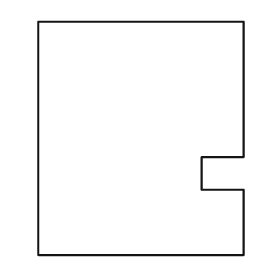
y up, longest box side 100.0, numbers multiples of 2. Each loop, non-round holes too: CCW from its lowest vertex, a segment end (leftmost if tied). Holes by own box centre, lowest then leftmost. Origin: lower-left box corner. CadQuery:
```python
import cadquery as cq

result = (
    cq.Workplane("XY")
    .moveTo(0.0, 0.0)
    .lineTo(88.0, 0.0)
    .lineTo(88.0, 28.0)
    .lineTo(70.0, 28.0)
    .lineTo(70.0, 42.0)
    .lineTo(88.0, 42.0)
    .lineTo(88.0, 100.0)
    .lineTo(0.0, 100.0)
    .close()
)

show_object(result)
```